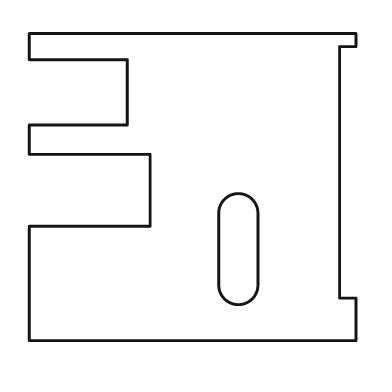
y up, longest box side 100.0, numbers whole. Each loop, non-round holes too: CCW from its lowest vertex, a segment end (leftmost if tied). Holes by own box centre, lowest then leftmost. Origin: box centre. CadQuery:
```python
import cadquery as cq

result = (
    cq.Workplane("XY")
    .moveTo(-50.0, -47.0)
    .lineTo(50.0, -47.0)
    .lineTo(50.0, -34.0)
    .lineTo(45.0, -34.0)
    .lineTo(45.0, 43.0)
    .lineTo(50.0, 43.0)
    .lineTo(50.0, 47.0)
    .lineTo(-50.0, 47.0)
    .lineTo(-50.0, 39.0)
    .lineTo(-20.0, 39.0)
    .lineTo(-20.0, 19.0)
    .lineTo(-50.0, 19.0)
    .lineTo(-50.0, 10.0)
    .lineTo(-13.0, 10.0)
    .lineTo(-13.0, -12.0)
    .lineTo(-50.0, -12.0)
    .close()
    .moveTo(8.0, -30.0)
    .threePointArc((14.0, -36.0), (20.0, -30.0))
    .lineTo(20.0, -8.0)
    .threePointArc((14.0, -2.0), (8.0, -8.0))
    .close()
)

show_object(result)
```